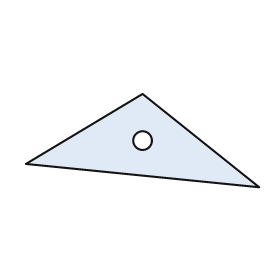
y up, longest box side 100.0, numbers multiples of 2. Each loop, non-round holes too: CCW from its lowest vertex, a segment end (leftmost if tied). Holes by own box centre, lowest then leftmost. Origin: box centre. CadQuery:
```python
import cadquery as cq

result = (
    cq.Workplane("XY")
    .moveTo(50.0, -20.0)
    .lineTo(0.0, 20.0)
    .lineTo(-50.0, -10.0)
    .close()
    .moveTo(0.0, 0.0)
    .circle(4.0)
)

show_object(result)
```